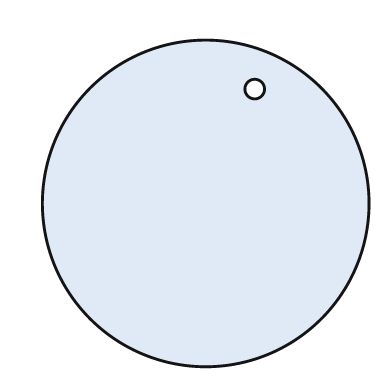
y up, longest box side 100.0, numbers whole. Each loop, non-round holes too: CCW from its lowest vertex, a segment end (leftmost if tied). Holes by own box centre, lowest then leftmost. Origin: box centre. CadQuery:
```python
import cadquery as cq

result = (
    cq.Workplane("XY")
    .moveTo(0.0, 0.0)
    .circle(50.0)
    .moveTo(15.0, 35.0)
    .circle(3.0)
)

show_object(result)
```